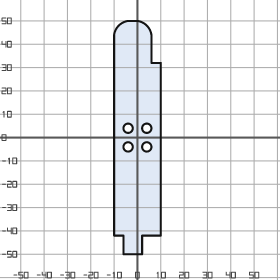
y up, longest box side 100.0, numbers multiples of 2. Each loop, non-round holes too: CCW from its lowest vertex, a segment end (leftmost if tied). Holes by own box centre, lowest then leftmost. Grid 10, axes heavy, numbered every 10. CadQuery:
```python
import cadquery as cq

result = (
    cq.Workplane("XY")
    .moveTo(-6.0, -50.0)
    .lineTo(2.0, -50.0)
    .lineTo(2.0, -42.0)
    .lineTo(10.0, -42.0)
    .lineTo(10.0, 32.0)
    .lineTo(6.0, 32.0)
    .lineTo(6.0, 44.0)
    .threePointArc((4.0, 48.0), (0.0, 50.0))
    .lineTo(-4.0, 50.0)
    .threePointArc((-8.0, 48.0), (-10.0, 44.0))
    .lineTo(-10.0, -42.0)
    .lineTo(-6.0, -42.0)
    .close()
    .moveTo(-4.0, -4.0)
    .circle(2.0)
    .moveTo(4.0, -4.0)
    .circle(2.0)
    .moveTo(-4.0, 4.0)
    .circle(2.0)
    .moveTo(4.0, 4.0)
    .circle(2.0)
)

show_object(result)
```